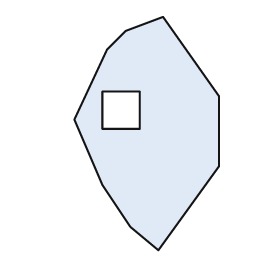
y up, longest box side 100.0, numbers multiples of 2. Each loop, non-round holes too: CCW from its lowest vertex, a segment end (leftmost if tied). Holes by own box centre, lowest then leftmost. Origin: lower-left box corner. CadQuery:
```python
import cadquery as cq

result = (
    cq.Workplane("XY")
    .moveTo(36.0, 0.0)
    .lineTo(62.0, 36.0)
    .lineTo(62.0, 66.0)
    .lineTo(38.0, 100.0)
    .lineTo(22.0, 94.0)
    .lineTo(14.0, 86.0)
    .lineTo(0.0, 56.0)
    .lineTo(12.0, 28.0)
    .lineTo(24.0, 10.0)
    .close()
    .moveTo(12.0, 52.0)
    .lineTo(28.0, 52.0)
    .lineTo(28.0, 68.0)
    .lineTo(12.0, 68.0)
    .close()
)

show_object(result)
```